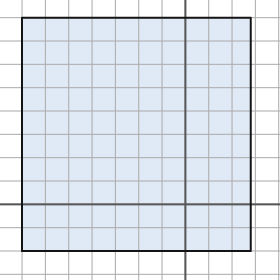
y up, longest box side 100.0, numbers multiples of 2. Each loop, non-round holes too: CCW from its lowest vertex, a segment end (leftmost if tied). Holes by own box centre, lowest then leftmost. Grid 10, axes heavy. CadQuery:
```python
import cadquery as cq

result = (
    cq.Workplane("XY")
    .moveTo(-70.0, -20.0)
    .lineTo(28.0, -20.0)
    .lineTo(28.0, 80.0)
    .lineTo(-70.0, 80.0)
    .close()
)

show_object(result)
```